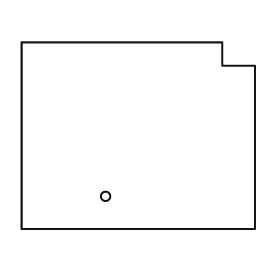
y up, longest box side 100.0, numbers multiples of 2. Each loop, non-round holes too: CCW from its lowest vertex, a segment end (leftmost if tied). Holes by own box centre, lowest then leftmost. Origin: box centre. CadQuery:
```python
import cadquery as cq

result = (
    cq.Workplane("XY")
    .moveTo(-50.0, -40.0)
    .lineTo(50.0, -40.0)
    .lineTo(50.0, 30.0)
    .lineTo(36.0, 30.0)
    .lineTo(36.0, 40.0)
    .lineTo(-50.0, 40.0)
    .close()
    .moveTo(-14.0, -26.0)
    .circle(2.0)
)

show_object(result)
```